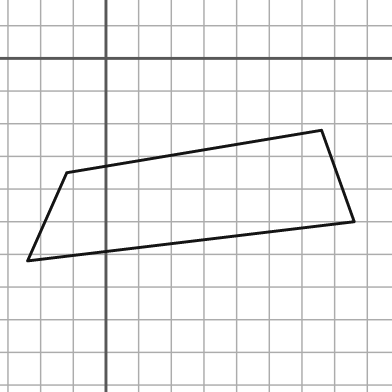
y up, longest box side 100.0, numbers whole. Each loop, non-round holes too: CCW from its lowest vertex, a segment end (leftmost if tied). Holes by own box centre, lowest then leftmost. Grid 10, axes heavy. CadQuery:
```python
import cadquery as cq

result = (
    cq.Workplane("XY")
    .moveTo(-24.0, -62.0)
    .lineTo(76.0, -50.0)
    .lineTo(66.0, -22.0)
    .lineTo(-12.0, -35.0)
    .close()
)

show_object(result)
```